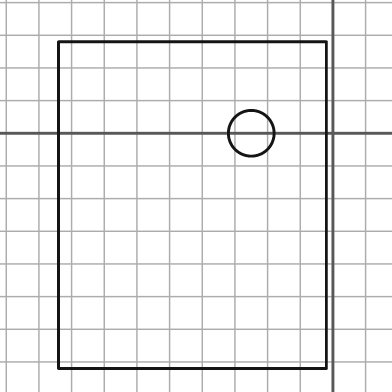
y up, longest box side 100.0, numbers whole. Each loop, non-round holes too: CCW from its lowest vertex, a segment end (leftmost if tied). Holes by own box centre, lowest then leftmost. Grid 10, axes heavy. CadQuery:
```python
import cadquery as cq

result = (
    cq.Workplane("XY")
    .moveTo(-84.0, -72.0)
    .lineTo(-2.0, -72.0)
    .lineTo(-2.0, 28.0)
    .lineTo(-84.0, 28.0)
    .close()
    .moveTo(-25.0, 0.0)
    .circle(7.0)
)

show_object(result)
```